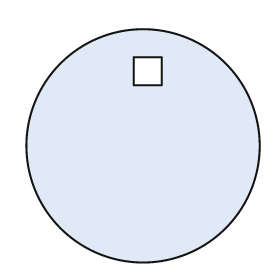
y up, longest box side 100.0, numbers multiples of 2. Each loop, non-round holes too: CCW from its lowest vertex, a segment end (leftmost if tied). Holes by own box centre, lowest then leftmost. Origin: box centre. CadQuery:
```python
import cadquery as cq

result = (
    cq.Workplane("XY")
    .moveTo(0.0, 0.0)
    .circle(50.0)
    .moveTo(-4.0, 26.0)
    .lineTo(8.0, 26.0)
    .lineTo(8.0, 38.0)
    .lineTo(-4.0, 38.0)
    .close()
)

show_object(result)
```